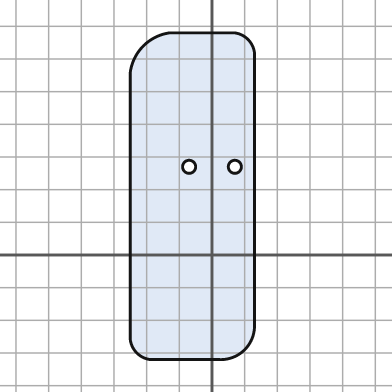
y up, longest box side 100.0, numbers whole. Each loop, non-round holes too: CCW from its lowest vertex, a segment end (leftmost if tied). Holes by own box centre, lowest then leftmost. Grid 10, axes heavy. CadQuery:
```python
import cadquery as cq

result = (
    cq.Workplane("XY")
    .moveTo(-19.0, -32.0)
    .lineTo(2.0, -32.0)
    .threePointArc((10.0, -29.0), (13.0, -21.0))
    .lineTo(13.0, 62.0)
    .threePointArc((11.0, 66.0), (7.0, 68.0))
    .lineTo(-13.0, 68.0)
    .threePointArc((-21.0, 64.0), (-25.0, 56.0))
    .lineTo(-25.0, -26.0)
    .threePointArc((-23.0, -30.0), (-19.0, -32.0))
    .close()
    .moveTo(-7.0, 27.0)
    .circle(2.0)
    .moveTo(7.0, 27.0)
    .circle(2.0)
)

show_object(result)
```